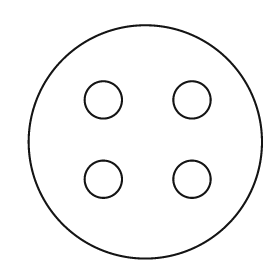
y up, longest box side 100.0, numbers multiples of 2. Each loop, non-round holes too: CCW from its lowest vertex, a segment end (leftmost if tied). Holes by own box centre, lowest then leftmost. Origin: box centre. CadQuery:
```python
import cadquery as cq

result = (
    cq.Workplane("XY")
    .moveTo(0.0, 0.0)
    .circle(50.0)
    .moveTo(-18.0, -16.0)
    .circle(8.0)
    .moveTo(20.0, -16.0)
    .circle(8.0)
    .moveTo(-18.0, 18.0)
    .circle(8.0)
    .moveTo(20.0, 18.0)
    .circle(8.0)
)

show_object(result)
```